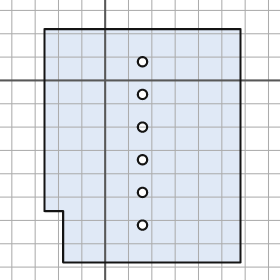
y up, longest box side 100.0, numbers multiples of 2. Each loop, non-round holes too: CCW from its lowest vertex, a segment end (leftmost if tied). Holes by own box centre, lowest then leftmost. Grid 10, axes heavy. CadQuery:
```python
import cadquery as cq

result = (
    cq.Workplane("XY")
    .moveTo(-18.0, -78.0)
    .lineTo(58.0, -78.0)
    .lineTo(58.0, 22.0)
    .lineTo(-26.0, 22.0)
    .lineTo(-26.0, -56.0)
    .lineTo(-18.0, -56.0)
    .close()
    .moveTo(16.0, -62.0)
    .circle(2.0)
    .moveTo(16.0, -48.0)
    .circle(2.0)
    .moveTo(16.0, -34.0)
    .circle(2.0)
    .moveTo(16.0, -20.0)
    .circle(2.0)
    .moveTo(16.0, -6.0)
    .circle(2.0)
    .moveTo(16.0, 8.0)
    .circle(2.0)
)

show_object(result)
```